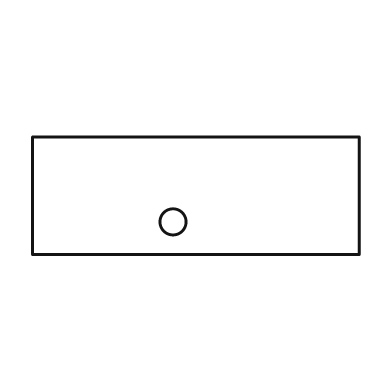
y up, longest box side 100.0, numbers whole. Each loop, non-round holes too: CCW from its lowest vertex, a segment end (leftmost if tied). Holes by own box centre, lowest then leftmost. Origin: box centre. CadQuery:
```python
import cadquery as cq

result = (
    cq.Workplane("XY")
    .moveTo(-50.0, -18.0)
    .lineTo(50.0, -18.0)
    .lineTo(50.0, 18.0)
    .lineTo(-50.0, 18.0)
    .close()
    .moveTo(-7.0, -8.0)
    .circle(4.0)
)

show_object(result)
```